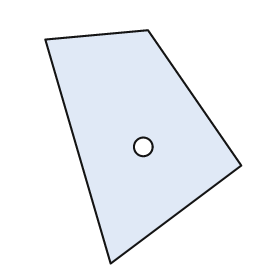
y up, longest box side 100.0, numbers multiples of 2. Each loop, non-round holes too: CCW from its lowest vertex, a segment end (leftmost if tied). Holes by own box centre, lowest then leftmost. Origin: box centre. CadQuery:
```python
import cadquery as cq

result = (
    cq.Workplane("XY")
    .moveTo(-14.0, -50.0)
    .lineTo(42.0, -8.0)
    .lineTo(2.0, 50.0)
    .lineTo(-42.0, 46.0)
    .close()
    .moveTo(0.0, 0.0)
    .circle(4.0)
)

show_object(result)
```